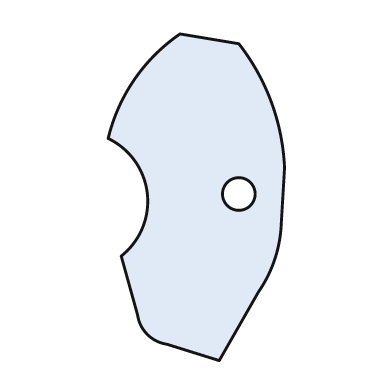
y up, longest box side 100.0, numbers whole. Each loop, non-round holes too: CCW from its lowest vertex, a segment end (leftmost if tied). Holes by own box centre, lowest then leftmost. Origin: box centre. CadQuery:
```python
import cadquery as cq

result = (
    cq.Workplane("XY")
    .moveTo(7.0, -50.0)
    .lineTo(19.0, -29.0)
    .threePointArc((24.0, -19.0), (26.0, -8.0))
    .lineTo(27.0, 9.0)
    .threePointArc((23.0, 29.0), (13.0, 47.0))
    .lineTo(-5.0, 50.0)
    .threePointArc((-19.0, 36.0), (-27.0, 18.0))
    .threePointArc((-15.0, 1.0), (-23.0, -18.0))
    .lineTo(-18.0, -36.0)
    .threePointArc((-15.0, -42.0), (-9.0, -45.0))
    .close()
    .moveTo(13.0, 1.0)
    .circle(5.0)
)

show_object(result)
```